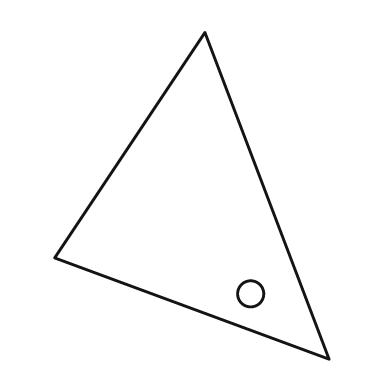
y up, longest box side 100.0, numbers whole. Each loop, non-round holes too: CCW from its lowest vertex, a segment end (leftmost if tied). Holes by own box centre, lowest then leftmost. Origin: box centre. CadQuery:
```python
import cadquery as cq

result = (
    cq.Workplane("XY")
    .moveTo(42.0, -50.0)
    .lineTo(4.0, 50.0)
    .lineTo(-42.0, -19.0)
    .close()
    .moveTo(18.0, -30.0)
    .circle(4.0)
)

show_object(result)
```